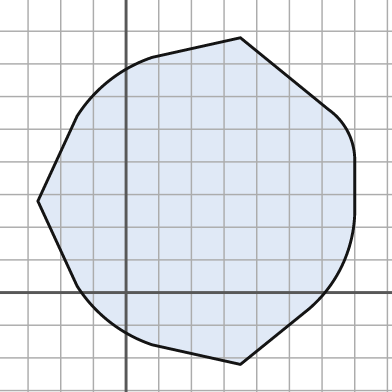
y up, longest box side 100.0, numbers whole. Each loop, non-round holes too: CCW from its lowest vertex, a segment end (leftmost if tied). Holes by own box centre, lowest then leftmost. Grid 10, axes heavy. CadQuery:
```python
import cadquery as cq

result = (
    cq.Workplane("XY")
    .moveTo(35.0, -22.0)
    .lineTo(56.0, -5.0)
    .threePointArc((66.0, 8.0), (70.0, 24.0))
    .lineTo(70.0, 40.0)
    .threePointArc((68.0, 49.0), (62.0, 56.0))
    .lineTo(35.0, 78.0)
    .lineTo(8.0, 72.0)
    .threePointArc((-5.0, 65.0), (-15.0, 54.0))
    .lineTo(-27.0, 28.0)
    .lineTo(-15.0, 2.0)
    .threePointArc((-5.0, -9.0), (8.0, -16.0))
    .close()
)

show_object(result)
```